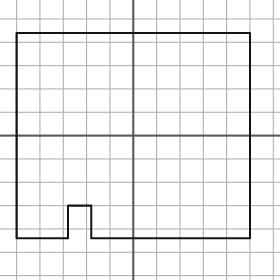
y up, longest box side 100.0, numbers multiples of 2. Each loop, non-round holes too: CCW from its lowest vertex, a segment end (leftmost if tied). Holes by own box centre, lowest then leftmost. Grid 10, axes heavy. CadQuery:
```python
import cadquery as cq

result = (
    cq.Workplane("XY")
    .moveTo(-50.0, -44.0)
    .lineTo(-28.0, -44.0)
    .lineTo(-28.0, -30.0)
    .lineTo(-18.0, -30.0)
    .lineTo(-18.0, -44.0)
    .lineTo(50.0, -44.0)
    .lineTo(50.0, 44.0)
    .lineTo(-50.0, 44.0)
    .close()
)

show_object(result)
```